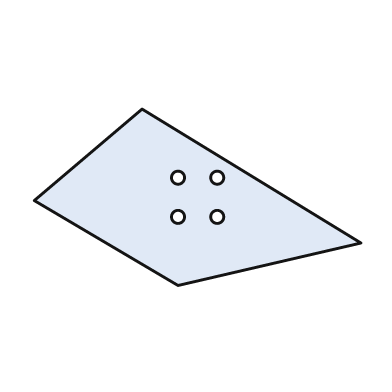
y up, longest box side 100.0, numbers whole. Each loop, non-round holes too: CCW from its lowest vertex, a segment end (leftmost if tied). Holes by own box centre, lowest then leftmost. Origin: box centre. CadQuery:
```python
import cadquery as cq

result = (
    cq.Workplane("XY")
    .moveTo(-6.0, -27.0)
    .lineTo(50.0, -14.0)
    .lineTo(-17.0, 27.0)
    .lineTo(-50.0, -1.0)
    .close()
    .moveTo(-6.0, -6.0)
    .circle(2.0)
    .moveTo(6.0, -6.0)
    .circle(2.0)
    .moveTo(-6.0, 6.0)
    .circle(2.0)
    .moveTo(6.0, 6.0)
    .circle(2.0)
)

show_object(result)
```